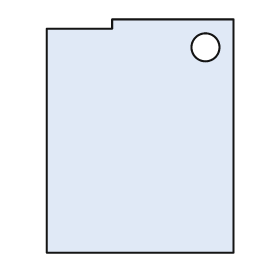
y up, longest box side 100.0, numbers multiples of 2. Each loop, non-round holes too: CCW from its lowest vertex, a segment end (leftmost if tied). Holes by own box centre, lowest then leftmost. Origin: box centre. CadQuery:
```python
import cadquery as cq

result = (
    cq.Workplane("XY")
    .moveTo(-40.0, -50.0)
    .lineTo(40.0, -50.0)
    .lineTo(40.0, 50.0)
    .lineTo(-12.0, 50.0)
    .lineTo(-12.0, 46.0)
    .lineTo(-40.0, 46.0)
    .close()
    .moveTo(28.0, 38.0)
    .circle(6.0)
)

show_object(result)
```